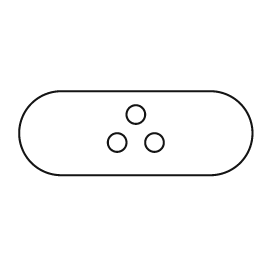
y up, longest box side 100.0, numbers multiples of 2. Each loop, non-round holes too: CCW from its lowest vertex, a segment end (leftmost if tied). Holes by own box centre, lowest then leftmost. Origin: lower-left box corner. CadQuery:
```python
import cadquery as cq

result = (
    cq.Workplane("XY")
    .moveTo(18.0, 0.0)
    .lineTo(82.0, 0.0)
    .threePointArc((100.0, 18.0), (82.0, 36.0))
    .lineTo(18.0, 36.0)
    .threePointArc((0.0, 18.0), (18.0, 0.0))
    .close()
    .moveTo(42.0, 14.0)
    .circle(4.0)
    .moveTo(58.0, 14.0)
    .circle(4.0)
    .moveTo(50.0, 26.0)
    .circle(4.0)
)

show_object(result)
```